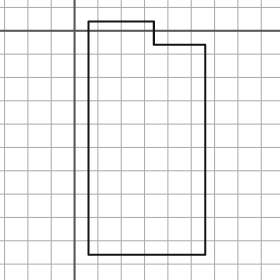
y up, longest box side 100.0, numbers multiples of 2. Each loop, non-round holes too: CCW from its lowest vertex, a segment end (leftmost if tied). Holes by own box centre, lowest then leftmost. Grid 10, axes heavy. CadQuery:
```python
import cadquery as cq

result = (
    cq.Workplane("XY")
    .moveTo(6.0, -96.0)
    .lineTo(56.0, -96.0)
    .lineTo(56.0, -6.0)
    .lineTo(34.0, -6.0)
    .lineTo(34.0, 4.0)
    .lineTo(6.0, 4.0)
    .close()
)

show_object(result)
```